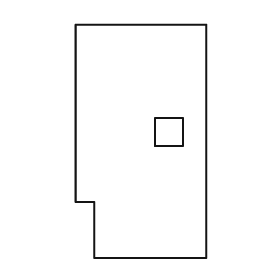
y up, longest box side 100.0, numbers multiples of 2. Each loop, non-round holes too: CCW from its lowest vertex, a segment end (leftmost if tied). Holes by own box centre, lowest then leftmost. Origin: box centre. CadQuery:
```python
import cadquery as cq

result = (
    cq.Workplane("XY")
    .moveTo(-20.0, -50.0)
    .lineTo(28.0, -50.0)
    .lineTo(28.0, 50.0)
    .lineTo(-28.0, 50.0)
    .lineTo(-28.0, -26.0)
    .lineTo(-20.0, -26.0)
    .close()
    .moveTo(6.0, -2.0)
    .lineTo(18.0, -2.0)
    .lineTo(18.0, 10.0)
    .lineTo(6.0, 10.0)
    .close()
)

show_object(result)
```